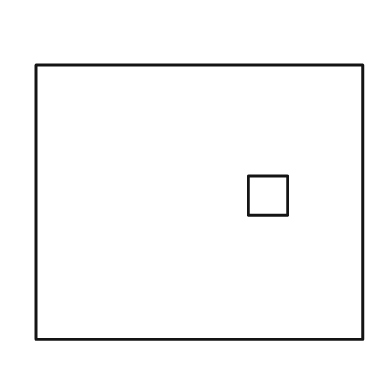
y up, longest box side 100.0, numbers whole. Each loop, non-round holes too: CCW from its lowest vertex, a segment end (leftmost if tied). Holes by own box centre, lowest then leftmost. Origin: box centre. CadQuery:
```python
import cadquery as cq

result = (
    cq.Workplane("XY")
    .moveTo(-50.0, -42.0)
    .lineTo(50.0, -42.0)
    .lineTo(50.0, 42.0)
    .lineTo(-50.0, 42.0)
    .close()
    .moveTo(15.0, -4.0)
    .lineTo(27.0, -4.0)
    .lineTo(27.0, 8.0)
    .lineTo(15.0, 8.0)
    .close()
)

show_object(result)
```